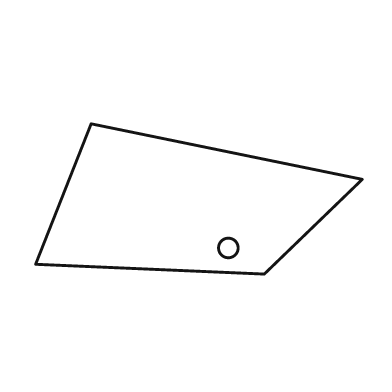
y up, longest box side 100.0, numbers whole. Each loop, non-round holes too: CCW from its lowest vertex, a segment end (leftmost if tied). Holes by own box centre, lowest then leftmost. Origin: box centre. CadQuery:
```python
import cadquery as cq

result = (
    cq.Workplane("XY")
    .moveTo(20.0, -23.0)
    .lineTo(50.0, 6.0)
    .lineTo(-33.0, 23.0)
    .lineTo(-50.0, -20.0)
    .close()
    .moveTo(9.0, -15.0)
    .circle(3.0)
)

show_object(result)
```